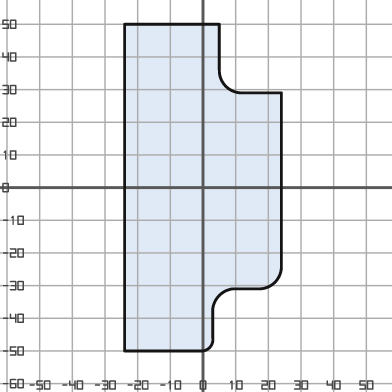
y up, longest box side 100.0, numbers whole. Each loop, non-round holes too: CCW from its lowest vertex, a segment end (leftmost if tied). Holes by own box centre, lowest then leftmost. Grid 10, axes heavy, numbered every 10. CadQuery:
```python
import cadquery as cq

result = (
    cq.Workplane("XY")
    .moveTo(-24.0, -50.0)
    .lineTo(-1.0, -50.0)
    .threePointArc((2.0, -49.0), (3.0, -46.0))
    .lineTo(3.0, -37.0)
    .threePointArc((5.0, -33.0), (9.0, -31.0))
    .lineTo(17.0, -31.0)
    .threePointArc((22.0, -29.0), (24.0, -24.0))
    .lineTo(24.0, 29.0)
    .lineTo(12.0, 29.0)
    .threePointArc((7.0, 31.0), (5.0, 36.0))
    .lineTo(5.0, 50.0)
    .lineTo(-24.0, 50.0)
    .close()
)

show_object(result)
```